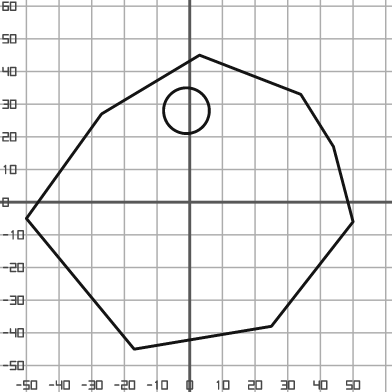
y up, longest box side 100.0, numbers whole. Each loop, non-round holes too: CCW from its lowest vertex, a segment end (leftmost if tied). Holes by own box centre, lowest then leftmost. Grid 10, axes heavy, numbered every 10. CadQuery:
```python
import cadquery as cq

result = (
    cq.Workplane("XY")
    .moveTo(-17.0, -45.0)
    .lineTo(25.0, -38.0)
    .lineTo(50.0, -6.0)
    .lineTo(44.0, 17.0)
    .lineTo(34.0, 33.0)
    .lineTo(3.0, 45.0)
    .lineTo(-27.0, 27.0)
    .lineTo(-50.0, -5.0)
    .close()
    .moveTo(-1.0, 28.0)
    .circle(7.0)
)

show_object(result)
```